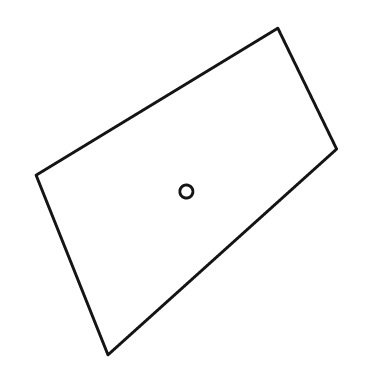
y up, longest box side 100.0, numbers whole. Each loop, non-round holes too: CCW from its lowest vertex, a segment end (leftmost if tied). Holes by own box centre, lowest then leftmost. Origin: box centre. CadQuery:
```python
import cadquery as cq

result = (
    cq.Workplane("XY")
    .moveTo(-24.0, -50.0)
    .lineTo(46.0, 13.0)
    .lineTo(28.0, 50.0)
    .lineTo(-46.0, 5.0)
    .close()
    .moveTo(0.0, 0.0)
    .circle(2.0)
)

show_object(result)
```